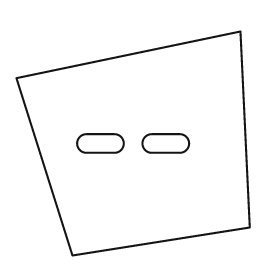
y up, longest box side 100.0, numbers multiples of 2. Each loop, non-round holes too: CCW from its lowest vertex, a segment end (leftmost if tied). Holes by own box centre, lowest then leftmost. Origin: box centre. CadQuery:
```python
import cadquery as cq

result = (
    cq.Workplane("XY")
    .moveTo(-26.0, -48.0)
    .lineTo(50.0, -36.0)
    .lineTo(46.0, 48.0)
    .lineTo(-50.0, 28.0)
    .close()
    .moveTo(-20.0, -4.0)
    .lineTo(-8.0, -4.0)
    .threePointArc((-4.0, 0.0), (-8.0, 4.0))
    .lineTo(-20.0, 4.0)
    .threePointArc((-24.0, 0.0), (-20.0, -4.0))
    .close()
    .moveTo(8.0, -4.0)
    .lineTo(20.0, -4.0)
    .threePointArc((24.0, 0.0), (20.0, 4.0))
    .lineTo(8.0, 4.0)
    .threePointArc((4.0, 0.0), (8.0, -4.0))
    .close()
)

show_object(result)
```